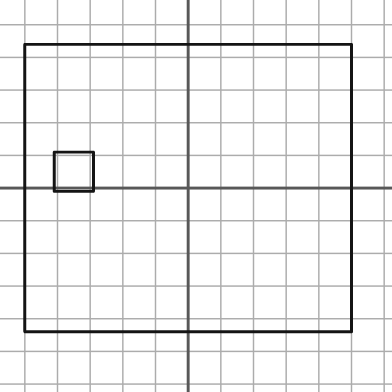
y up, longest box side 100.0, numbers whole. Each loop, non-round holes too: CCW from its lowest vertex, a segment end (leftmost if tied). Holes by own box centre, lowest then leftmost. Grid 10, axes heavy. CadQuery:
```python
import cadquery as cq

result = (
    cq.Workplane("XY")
    .moveTo(-50.0, -44.0)
    .lineTo(50.0, -44.0)
    .lineTo(50.0, 44.0)
    .lineTo(-50.0, 44.0)
    .close()
    .moveTo(-41.0, -1.0)
    .lineTo(-29.0, -1.0)
    .lineTo(-29.0, 11.0)
    .lineTo(-41.0, 11.0)
    .close()
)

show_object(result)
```